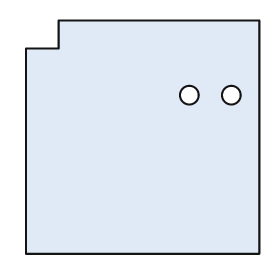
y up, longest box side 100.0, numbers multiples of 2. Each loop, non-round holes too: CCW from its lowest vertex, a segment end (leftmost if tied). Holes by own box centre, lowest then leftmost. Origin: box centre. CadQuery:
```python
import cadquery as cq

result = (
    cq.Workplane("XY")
    .moveTo(-50.0, -50.0)
    .lineTo(50.0, -50.0)
    .lineTo(50.0, 50.0)
    .lineTo(-36.0, 50.0)
    .lineTo(-36.0, 38.0)
    .lineTo(-50.0, 38.0)
    .close()
    .moveTo(20.0, 18.0)
    .circle(4.0)
    .moveTo(38.0, 18.0)
    .circle(4.0)
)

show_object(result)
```